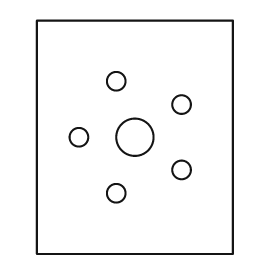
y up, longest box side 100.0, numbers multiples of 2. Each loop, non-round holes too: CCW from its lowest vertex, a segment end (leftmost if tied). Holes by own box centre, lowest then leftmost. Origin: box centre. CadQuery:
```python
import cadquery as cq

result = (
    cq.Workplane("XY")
    .moveTo(-42.0, -50.0)
    .lineTo(42.0, -50.0)
    .lineTo(42.0, 50.0)
    .lineTo(-42.0, 50.0)
    .close()
    .moveTo(-8.0, -24.0)
    .circle(4.0)
    .moveTo(20.0, -14.0)
    .circle(4.0)
    .moveTo(-24.0, 0.0)
    .circle(4.0)
    .moveTo(0.0, 0.0)
    .circle(8.0)
    .moveTo(20.0, 14.0)
    .circle(4.0)
    .moveTo(-8.0, 24.0)
    .circle(4.0)
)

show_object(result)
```